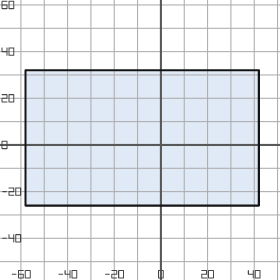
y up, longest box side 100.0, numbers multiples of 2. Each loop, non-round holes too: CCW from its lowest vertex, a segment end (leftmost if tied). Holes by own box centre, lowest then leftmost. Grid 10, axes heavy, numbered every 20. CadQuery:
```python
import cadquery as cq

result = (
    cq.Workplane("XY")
    .moveTo(-58.0, -26.0)
    .lineTo(42.0, -26.0)
    .lineTo(42.0, 32.0)
    .lineTo(-58.0, 32.0)
    .close()
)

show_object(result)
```